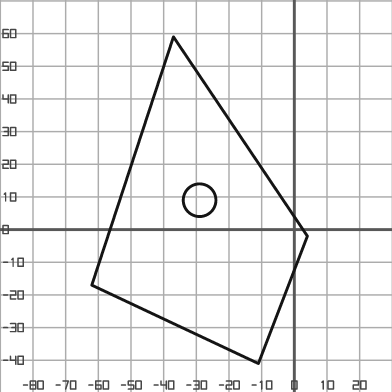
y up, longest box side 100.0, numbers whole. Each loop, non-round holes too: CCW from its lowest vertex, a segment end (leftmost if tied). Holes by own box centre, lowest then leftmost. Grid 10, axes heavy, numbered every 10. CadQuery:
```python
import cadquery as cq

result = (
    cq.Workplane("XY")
    .moveTo(-11.0, -41.0)
    .lineTo(4.0, -2.0)
    .lineTo(-37.0, 59.0)
    .lineTo(-62.0, -17.0)
    .close()
    .moveTo(-29.0, 9.0)
    .circle(5.0)
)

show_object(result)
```